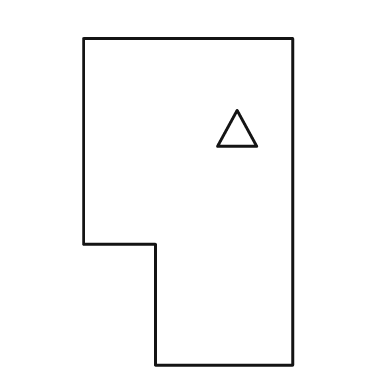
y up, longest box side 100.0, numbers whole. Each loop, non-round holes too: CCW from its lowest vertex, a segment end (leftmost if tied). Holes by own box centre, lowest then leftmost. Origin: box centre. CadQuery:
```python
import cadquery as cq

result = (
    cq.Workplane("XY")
    .moveTo(-10.0, -50.0)
    .lineTo(32.0, -50.0)
    .lineTo(32.0, 50.0)
    .lineTo(-32.0, 50.0)
    .lineTo(-32.0, -13.0)
    .lineTo(-10.0, -13.0)
    .close()
    .moveTo(9.0, 17.0)
    .lineTo(21.0, 17.0)
    .lineTo(15.0, 28.0)
    .close()
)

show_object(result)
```